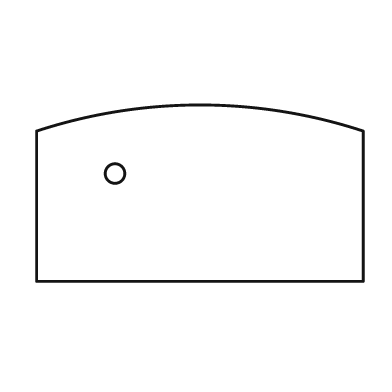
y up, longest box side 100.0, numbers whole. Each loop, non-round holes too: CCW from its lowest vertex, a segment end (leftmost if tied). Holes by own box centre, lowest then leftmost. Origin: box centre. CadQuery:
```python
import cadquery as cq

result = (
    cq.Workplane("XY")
    .moveTo(-50.0, -27.0)
    .lineTo(50.0, -27.0)
    .lineTo(50.0, 19.0)
    .threePointArc((0.0, 27.0), (-50.0, 19.0))
    .close()
    .moveTo(-26.0, 6.0)
    .circle(3.0)
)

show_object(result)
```